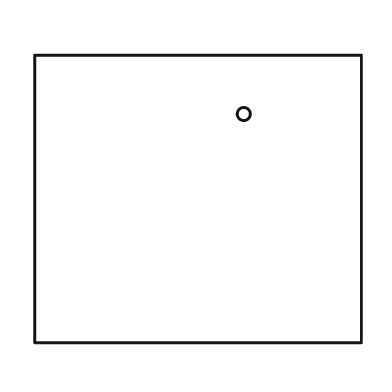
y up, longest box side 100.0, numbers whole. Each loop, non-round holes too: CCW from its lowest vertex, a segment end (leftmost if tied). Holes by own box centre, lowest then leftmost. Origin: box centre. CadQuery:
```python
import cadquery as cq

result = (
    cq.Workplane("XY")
    .moveTo(-50.0, -44.0)
    .lineTo(50.0, -44.0)
    .lineTo(50.0, 44.0)
    .lineTo(-50.0, 44.0)
    .close()
    .moveTo(14.0, 26.0)
    .circle(2.0)
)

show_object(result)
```